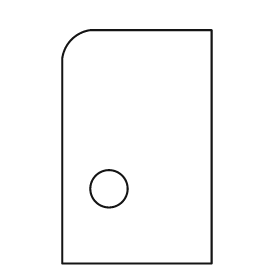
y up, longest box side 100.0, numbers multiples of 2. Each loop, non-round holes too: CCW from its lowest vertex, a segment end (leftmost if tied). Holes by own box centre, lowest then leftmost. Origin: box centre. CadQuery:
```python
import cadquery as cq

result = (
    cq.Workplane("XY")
    .moveTo(-32.0, -50.0)
    .lineTo(32.0, -50.0)
    .lineTo(32.0, 50.0)
    .lineTo(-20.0, 50.0)
    .threePointArc((-28.0, 46.0), (-32.0, 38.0))
    .close()
    .moveTo(-12.0, -18.0)
    .circle(8.0)
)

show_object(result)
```